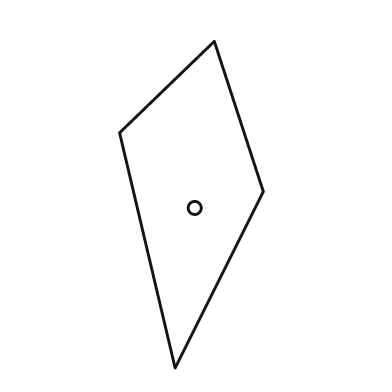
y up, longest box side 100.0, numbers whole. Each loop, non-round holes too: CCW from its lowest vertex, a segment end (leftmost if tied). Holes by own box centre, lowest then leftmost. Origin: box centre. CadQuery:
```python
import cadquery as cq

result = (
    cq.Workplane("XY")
    .moveTo(-5.0, -50.0)
    .lineTo(22.0, 4.0)
    .lineTo(7.0, 50.0)
    .lineTo(-22.0, 22.0)
    .close()
    .moveTo(1.0, -1.0)
    .circle(2.0)
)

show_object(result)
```